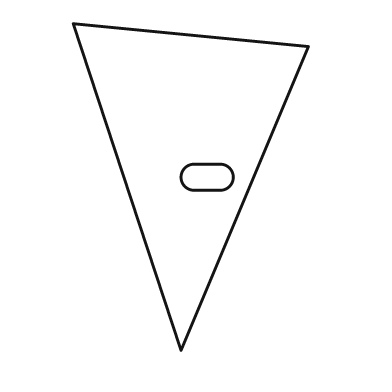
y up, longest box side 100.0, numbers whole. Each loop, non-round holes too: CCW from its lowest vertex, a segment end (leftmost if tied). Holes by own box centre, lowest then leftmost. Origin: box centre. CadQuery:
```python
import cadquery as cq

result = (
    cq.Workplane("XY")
    .moveTo(-3.0, -50.0)
    .lineTo(36.0, 43.0)
    .lineTo(-36.0, 50.0)
    .close()
    .moveTo(1.0, -1.0)
    .lineTo(9.0, -1.0)
    .threePointArc((13.0, 3.0), (9.0, 7.0))
    .lineTo(1.0, 7.0)
    .threePointArc((-3.0, 3.0), (1.0, -1.0))
    .close()
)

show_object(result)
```